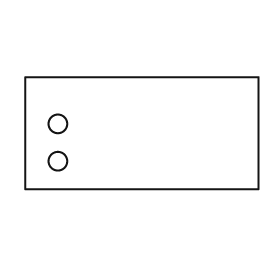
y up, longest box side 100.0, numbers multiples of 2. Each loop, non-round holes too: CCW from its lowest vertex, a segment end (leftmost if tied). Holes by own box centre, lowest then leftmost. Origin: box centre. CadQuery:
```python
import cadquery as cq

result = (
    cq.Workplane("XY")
    .moveTo(-50.0, -24.0)
    .lineTo(50.0, -24.0)
    .lineTo(50.0, 24.0)
    .lineTo(-50.0, 24.0)
    .close()
    .moveTo(-36.0, -12.0)
    .circle(4.0)
    .moveTo(-36.0, 4.0)
    .circle(4.0)
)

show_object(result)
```